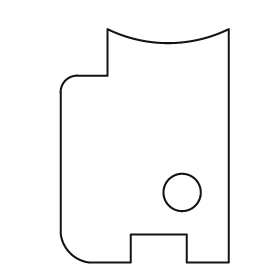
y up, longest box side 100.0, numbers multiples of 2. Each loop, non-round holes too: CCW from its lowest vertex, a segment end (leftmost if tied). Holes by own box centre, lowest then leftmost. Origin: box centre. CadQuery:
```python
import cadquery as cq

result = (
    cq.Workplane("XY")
    .moveTo(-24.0, -50.0)
    .lineTo(-6.0, -50.0)
    .lineTo(-6.0, -38.0)
    .lineTo(18.0, -38.0)
    .lineTo(18.0, -50.0)
    .lineTo(36.0, -50.0)
    .lineTo(36.0, 50.0)
    .threePointArc((10.0, 44.0), (-16.0, 50.0))
    .lineTo(-16.0, 30.0)
    .lineTo(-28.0, 30.0)
    .threePointArc((-34.0, 28.0), (-36.0, 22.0))
    .lineTo(-36.0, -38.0)
    .threePointArc((-32.0, -46.0), (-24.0, -50.0))
    .close()
    .moveTo(16.0, -20.0)
    .circle(8.0)
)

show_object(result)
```